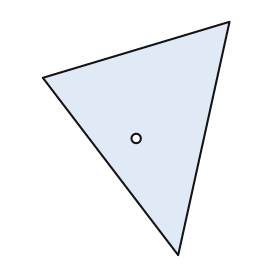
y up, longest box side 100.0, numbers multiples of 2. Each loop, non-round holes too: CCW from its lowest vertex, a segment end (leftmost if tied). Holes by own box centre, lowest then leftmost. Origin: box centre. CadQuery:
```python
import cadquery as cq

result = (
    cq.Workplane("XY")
    .moveTo(18.0, -50.0)
    .lineTo(40.0, 50.0)
    .lineTo(-40.0, 26.0)
    .close()
    .moveTo(0.0, 0.0)
    .circle(2.0)
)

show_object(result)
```